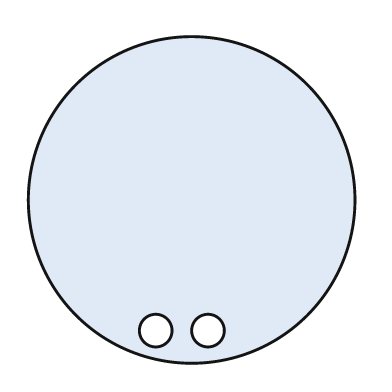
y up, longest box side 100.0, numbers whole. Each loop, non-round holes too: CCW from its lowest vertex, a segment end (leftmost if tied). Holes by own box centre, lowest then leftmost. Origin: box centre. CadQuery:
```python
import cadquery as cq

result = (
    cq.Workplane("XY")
    .moveTo(0.0, 0.0)
    .circle(50.0)
    .moveTo(-11.0, -40.0)
    .circle(5.0)
    .moveTo(5.0, -40.0)
    .circle(5.0)
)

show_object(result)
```